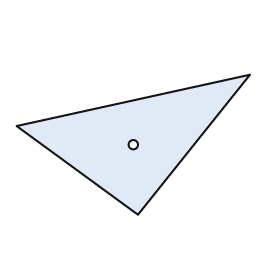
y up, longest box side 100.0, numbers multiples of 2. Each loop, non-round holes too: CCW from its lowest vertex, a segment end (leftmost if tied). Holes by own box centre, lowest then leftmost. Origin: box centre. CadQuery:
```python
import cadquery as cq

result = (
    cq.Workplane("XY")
    .moveTo(2.0, -30.0)
    .lineTo(50.0, 30.0)
    .lineTo(-50.0, 8.0)
    .close()
    .moveTo(0.0, 0.0)
    .circle(2.0)
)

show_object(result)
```